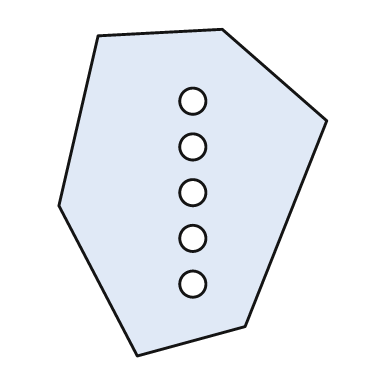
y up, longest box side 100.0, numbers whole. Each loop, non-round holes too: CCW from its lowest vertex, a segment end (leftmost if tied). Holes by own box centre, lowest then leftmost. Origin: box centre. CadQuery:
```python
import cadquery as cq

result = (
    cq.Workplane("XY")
    .moveTo(-17.0, -50.0)
    .lineTo(16.0, -41.0)
    .lineTo(41.0, 22.0)
    .lineTo(9.0, 50.0)
    .lineTo(-29.0, 48.0)
    .lineTo(-41.0, -4.0)
    .close()
    .moveTo(0.0, -28.0)
    .circle(4.0)
    .moveTo(0.0, -14.0)
    .circle(4.0)
    .moveTo(0.0, 0.0)
    .circle(4.0)
    .moveTo(0.0, 14.0)
    .circle(4.0)
    .moveTo(0.0, 28.0)
    .circle(4.0)
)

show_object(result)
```